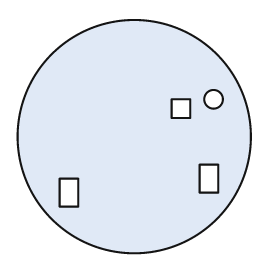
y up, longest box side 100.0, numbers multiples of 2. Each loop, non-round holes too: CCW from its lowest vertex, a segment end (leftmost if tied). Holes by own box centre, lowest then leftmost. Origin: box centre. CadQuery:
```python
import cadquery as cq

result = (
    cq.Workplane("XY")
    .moveTo(0.0, 0.0)
    .circle(50.0)
    .moveTo(-32.0, -30.0)
    .lineTo(-24.0, -30.0)
    .lineTo(-24.0, -18.0)
    .lineTo(-32.0, -18.0)
    .close()
    .moveTo(28.0, -24.0)
    .lineTo(36.0, -24.0)
    .lineTo(36.0, -12.0)
    .lineTo(28.0, -12.0)
    .close()
    .moveTo(16.0, 8.0)
    .lineTo(24.0, 8.0)
    .lineTo(24.0, 16.0)
    .lineTo(16.0, 16.0)
    .close()
    .moveTo(34.0, 16.0)
    .circle(4.0)
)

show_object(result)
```